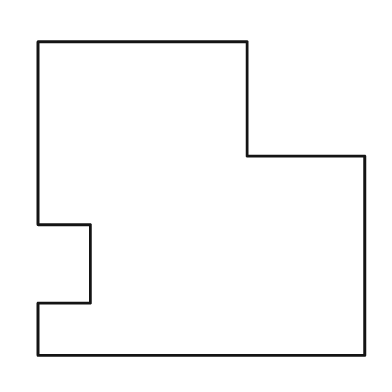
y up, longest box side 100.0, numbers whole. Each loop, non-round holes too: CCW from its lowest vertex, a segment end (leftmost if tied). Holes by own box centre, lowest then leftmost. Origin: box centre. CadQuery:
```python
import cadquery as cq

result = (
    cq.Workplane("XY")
    .moveTo(-50.0, -48.0)
    .lineTo(50.0, -48.0)
    .lineTo(50.0, 13.0)
    .lineTo(14.0, 13.0)
    .lineTo(14.0, 48.0)
    .lineTo(-50.0, 48.0)
    .lineTo(-50.0, -8.0)
    .lineTo(-34.0, -8.0)
    .lineTo(-34.0, -32.0)
    .lineTo(-50.0, -32.0)
    .close()
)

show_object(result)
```